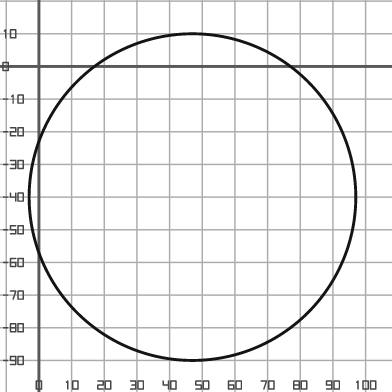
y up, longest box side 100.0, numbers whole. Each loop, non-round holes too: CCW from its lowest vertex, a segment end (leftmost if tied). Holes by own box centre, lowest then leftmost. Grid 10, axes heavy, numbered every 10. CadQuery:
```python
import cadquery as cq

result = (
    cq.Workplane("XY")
    .moveTo(47.0, -40.0)
    .circle(50.0)
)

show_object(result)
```